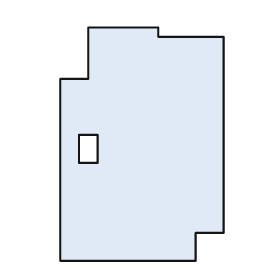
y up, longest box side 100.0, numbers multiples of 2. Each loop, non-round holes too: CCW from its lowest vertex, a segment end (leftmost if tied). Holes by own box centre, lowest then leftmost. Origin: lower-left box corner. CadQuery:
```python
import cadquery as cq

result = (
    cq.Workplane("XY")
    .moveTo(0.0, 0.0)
    .lineTo(58.0, 0.0)
    .lineTo(58.0, 12.0)
    .lineTo(70.0, 12.0)
    .lineTo(70.0, 96.0)
    .lineTo(42.0, 96.0)
    .lineTo(42.0, 100.0)
    .lineTo(12.0, 100.0)
    .lineTo(12.0, 78.0)
    .lineTo(0.0, 78.0)
    .close()
    .moveTo(8.0, 42.0)
    .lineTo(16.0, 42.0)
    .lineTo(16.0, 54.0)
    .lineTo(8.0, 54.0)
    .close()
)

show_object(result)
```